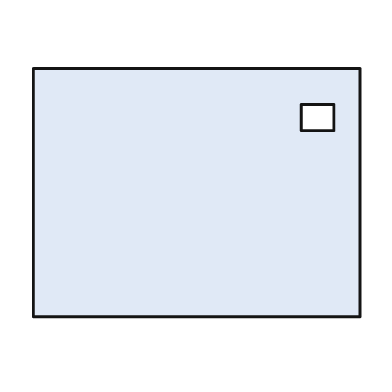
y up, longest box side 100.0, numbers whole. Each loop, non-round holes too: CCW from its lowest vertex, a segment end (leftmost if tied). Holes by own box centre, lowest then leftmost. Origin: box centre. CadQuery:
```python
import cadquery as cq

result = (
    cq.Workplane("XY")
    .moveTo(-50.0, -38.0)
    .lineTo(50.0, -38.0)
    .lineTo(50.0, 38.0)
    .lineTo(-50.0, 38.0)
    .close()
    .moveTo(32.0, 19.0)
    .lineTo(42.0, 19.0)
    .lineTo(42.0, 27.0)
    .lineTo(32.0, 27.0)
    .close()
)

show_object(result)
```